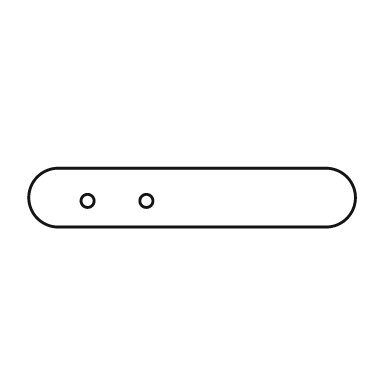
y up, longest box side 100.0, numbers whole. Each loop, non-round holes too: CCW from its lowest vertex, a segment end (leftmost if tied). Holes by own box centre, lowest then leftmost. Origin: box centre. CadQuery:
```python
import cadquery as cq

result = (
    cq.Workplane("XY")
    .moveTo(-41.0, -9.0)
    .lineTo(41.0, -9.0)
    .threePointArc((50.0, 0.0), (41.0, 9.0))
    .lineTo(-41.0, 9.0)
    .threePointArc((-50.0, 0.0), (-41.0, -9.0))
    .close()
    .moveTo(-32.0, -1.0)
    .circle(2.0)
    .moveTo(-14.0, -1.0)
    .circle(2.0)
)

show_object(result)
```